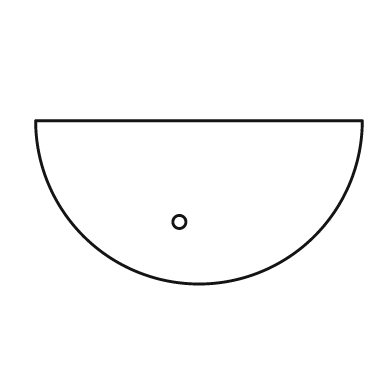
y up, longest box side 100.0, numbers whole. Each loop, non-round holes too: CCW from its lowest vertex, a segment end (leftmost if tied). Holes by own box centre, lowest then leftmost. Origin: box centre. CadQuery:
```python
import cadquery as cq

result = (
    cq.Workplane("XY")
    .moveTo(-50.0, 25.0)
    .threePointArc((0.0, -25.0), (50.0, 25.0))
    .close()
    .moveTo(-6.0, -6.0)
    .circle(2.0)
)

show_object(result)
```